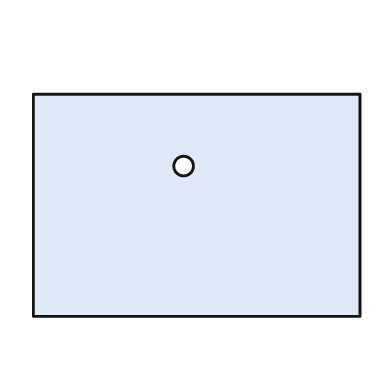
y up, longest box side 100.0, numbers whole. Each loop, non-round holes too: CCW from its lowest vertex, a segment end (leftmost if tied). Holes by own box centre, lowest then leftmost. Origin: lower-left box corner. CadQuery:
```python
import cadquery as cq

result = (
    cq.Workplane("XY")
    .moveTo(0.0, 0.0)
    .lineTo(100.0, 0.0)
    .lineTo(100.0, 68.0)
    .lineTo(0.0, 68.0)
    .close()
    .moveTo(46.0, 46.0)
    .circle(3.0)
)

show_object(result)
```